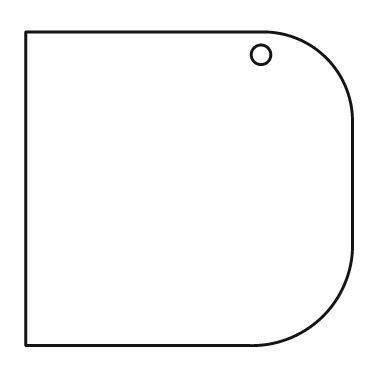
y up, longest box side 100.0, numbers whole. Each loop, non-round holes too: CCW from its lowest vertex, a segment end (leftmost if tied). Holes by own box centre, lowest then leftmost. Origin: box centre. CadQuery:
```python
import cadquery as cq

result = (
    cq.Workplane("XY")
    .moveTo(-50.0, -48.0)
    .lineTo(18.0, -48.0)
    .threePointArc((41.0, -39.0), (50.0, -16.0))
    .lineTo(50.0, 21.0)
    .threePointArc((42.0, 40.0), (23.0, 48.0))
    .lineTo(-50.0, 48.0)
    .close()
    .moveTo(22.0, 41.0)
    .circle(3.0)
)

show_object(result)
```